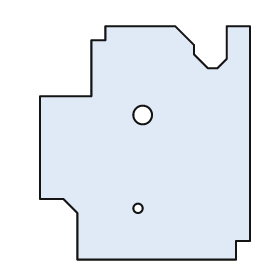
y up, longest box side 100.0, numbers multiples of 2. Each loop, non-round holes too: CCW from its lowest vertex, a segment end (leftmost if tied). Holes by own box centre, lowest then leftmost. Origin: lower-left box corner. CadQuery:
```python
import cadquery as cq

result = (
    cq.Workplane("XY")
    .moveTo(16.0, 0.0)
    .lineTo(84.0, 0.0)
    .lineTo(84.0, 8.0)
    .lineTo(90.0, 8.0)
    .lineTo(90.0, 100.0)
    .lineTo(80.0, 100.0)
    .lineTo(80.0, 86.0)
    .lineTo(76.0, 82.0)
    .lineTo(72.0, 82.0)
    .lineTo(66.0, 88.0)
    .lineTo(66.0, 92.0)
    .lineTo(58.0, 100.0)
    .lineTo(28.0, 100.0)
    .lineTo(28.0, 94.0)
    .lineTo(22.0, 94.0)
    .lineTo(22.0, 70.0)
    .lineTo(0.0, 70.0)
    .lineTo(0.0, 26.0)
    .lineTo(10.0, 26.0)
    .lineTo(16.0, 20.0)
    .close()
    .moveTo(42.0, 22.0)
    .circle(2.0)
    .moveTo(44.0, 62.0)
    .circle(4.0)
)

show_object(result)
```